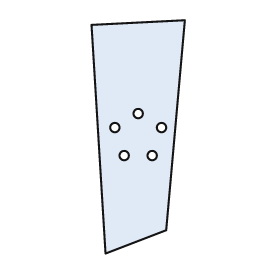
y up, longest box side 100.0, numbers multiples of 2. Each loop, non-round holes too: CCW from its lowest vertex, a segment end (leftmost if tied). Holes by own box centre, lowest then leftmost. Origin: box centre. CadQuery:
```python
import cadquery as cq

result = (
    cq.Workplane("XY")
    .moveTo(-14.0, -50.0)
    .lineTo(12.0, -40.0)
    .lineTo(20.0, 50.0)
    .lineTo(-20.0, 48.0)
    .close()
    .moveTo(-6.0, -8.0)
    .circle(2.0)
    .moveTo(6.0, -8.0)
    .circle(2.0)
    .moveTo(-10.0, 4.0)
    .circle(2.0)
    .moveTo(10.0, 4.0)
    .circle(2.0)
    .moveTo(0.0, 10.0)
    .circle(2.0)
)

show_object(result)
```